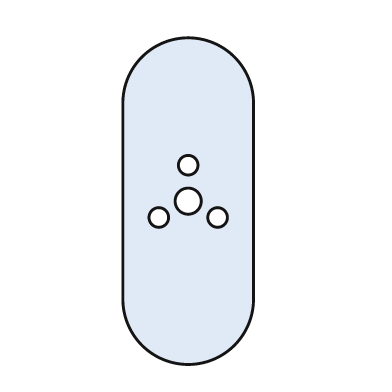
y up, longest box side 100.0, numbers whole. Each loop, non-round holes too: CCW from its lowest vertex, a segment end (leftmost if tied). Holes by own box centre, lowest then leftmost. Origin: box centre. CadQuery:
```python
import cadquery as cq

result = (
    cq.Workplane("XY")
    .moveTo(-20.0, -30.0)
    .threePointArc((0.0, -50.0), (20.0, -30.0))
    .lineTo(20.0, 30.0)
    .threePointArc((0.0, 50.0), (-20.0, 30.0))
    .close()
    .moveTo(-9.0, -5.0)
    .circle(3.0)
    .moveTo(9.0, -5.0)
    .circle(3.0)
    .moveTo(0.0, 0.0)
    .circle(4.0)
    .moveTo(0.0, 11.0)
    .circle(3.0)
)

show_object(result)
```